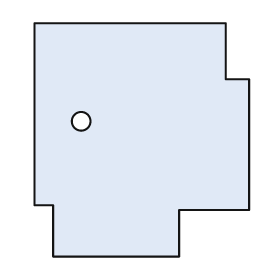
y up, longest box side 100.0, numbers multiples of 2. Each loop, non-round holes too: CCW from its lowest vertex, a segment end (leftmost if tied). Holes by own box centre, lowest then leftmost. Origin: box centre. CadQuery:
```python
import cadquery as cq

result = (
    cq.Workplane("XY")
    .moveTo(-38.0, -50.0)
    .lineTo(16.0, -50.0)
    .lineTo(16.0, -30.0)
    .lineTo(46.0, -30.0)
    .lineTo(46.0, 26.0)
    .lineTo(36.0, 26.0)
    .lineTo(36.0, 50.0)
    .lineTo(-46.0, 50.0)
    .lineTo(-46.0, -28.0)
    .lineTo(-38.0, -28.0)
    .close()
    .moveTo(-26.0, 8.0)
    .circle(4.0)
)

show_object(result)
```